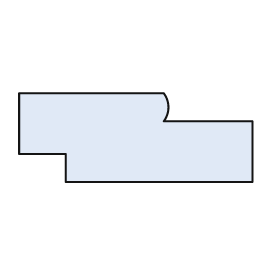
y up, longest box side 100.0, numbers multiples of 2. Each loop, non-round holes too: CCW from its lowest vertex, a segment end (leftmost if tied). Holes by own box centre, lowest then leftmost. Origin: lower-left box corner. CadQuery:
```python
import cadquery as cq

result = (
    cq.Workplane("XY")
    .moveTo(20.0, 0.0)
    .lineTo(100.0, 0.0)
    .lineTo(100.0, 26.0)
    .lineTo(62.0, 26.0)
    .threePointArc((64.0, 32.0), (62.0, 38.0))
    .lineTo(0.0, 38.0)
    .lineTo(0.0, 12.0)
    .lineTo(20.0, 12.0)
    .close()
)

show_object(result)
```